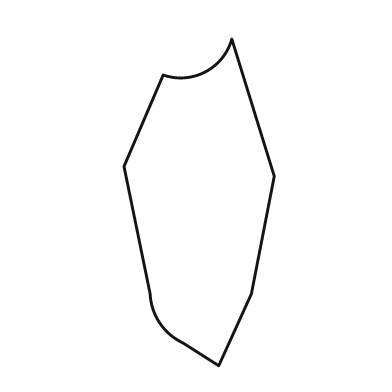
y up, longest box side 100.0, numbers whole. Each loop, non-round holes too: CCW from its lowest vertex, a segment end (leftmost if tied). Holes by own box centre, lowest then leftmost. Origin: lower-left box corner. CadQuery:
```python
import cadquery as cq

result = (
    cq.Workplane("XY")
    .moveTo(29.0, 0.0)
    .lineTo(39.0, 22.0)
    .lineTo(46.0, 58.0)
    .lineTo(33.0, 100.0)
    .threePointArc((25.0, 90.0), (12.0, 89.0))
    .lineTo(0.0, 61.0)
    .lineTo(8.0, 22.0)
    .threePointArc((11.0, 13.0), (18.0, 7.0))
    .close()
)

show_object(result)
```